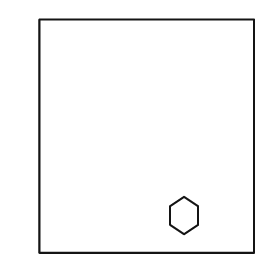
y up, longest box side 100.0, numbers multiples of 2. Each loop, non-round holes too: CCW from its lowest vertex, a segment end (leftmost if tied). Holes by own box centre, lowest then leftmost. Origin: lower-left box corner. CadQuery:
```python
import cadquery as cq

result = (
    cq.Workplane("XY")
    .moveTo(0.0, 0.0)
    .lineTo(92.0, 0.0)
    .lineTo(92.0, 100.0)
    .lineTo(0.0, 100.0)
    .close()
    .moveTo(62.0, 8.0)
    .lineTo(68.0, 12.0)
    .lineTo(68.0, 20.0)
    .lineTo(62.0, 24.0)
    .lineTo(56.0, 20.0)
    .lineTo(56.0, 12.0)
    .close()
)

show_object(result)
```